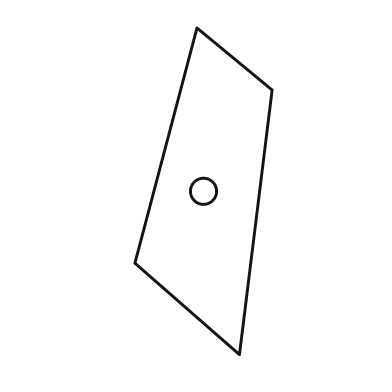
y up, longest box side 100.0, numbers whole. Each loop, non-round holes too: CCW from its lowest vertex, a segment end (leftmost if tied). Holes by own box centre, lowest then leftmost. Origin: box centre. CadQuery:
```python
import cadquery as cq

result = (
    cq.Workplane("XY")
    .moveTo(11.0, -50.0)
    .lineTo(21.0, 31.0)
    .lineTo(-2.0, 50.0)
    .lineTo(-21.0, -22.0)
    .close()
    .moveTo(0.0, 0.0)
    .circle(4.0)
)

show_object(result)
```